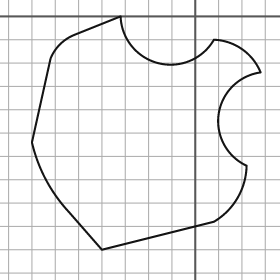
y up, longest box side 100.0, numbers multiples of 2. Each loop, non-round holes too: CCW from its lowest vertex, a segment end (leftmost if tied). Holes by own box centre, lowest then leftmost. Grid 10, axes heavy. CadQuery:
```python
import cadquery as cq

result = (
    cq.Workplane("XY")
    .moveTo(-40.0, -100.0)
    .lineTo(8.0, -88.0)
    .threePointArc((18.0, -78.0), (22.0, -64.0))
    .threePointArc((10.0, -42.0), (28.0, -24.0))
    .threePointArc((20.0, -14.0), (8.0, -10.0))
    .threePointArc((-16.0, -20.0), (-32.0, 0.0))
    .lineTo(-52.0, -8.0)
    .threePointArc((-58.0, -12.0), (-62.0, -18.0))
    .lineTo(-70.0, -54.0)
    .threePointArc((-64.0, -70.0), (-54.0, -84.0))
    .close()
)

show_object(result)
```